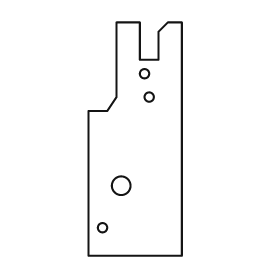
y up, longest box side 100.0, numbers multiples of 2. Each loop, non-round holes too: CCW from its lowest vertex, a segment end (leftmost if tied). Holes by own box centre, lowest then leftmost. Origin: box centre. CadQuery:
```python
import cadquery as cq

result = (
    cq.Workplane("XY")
    .moveTo(-20.0, -50.0)
    .lineTo(20.0, -50.0)
    .lineTo(20.0, 50.0)
    .lineTo(14.0, 50.0)
    .lineTo(10.0, 46.0)
    .lineTo(10.0, 34.0)
    .lineTo(2.0, 34.0)
    .lineTo(2.0, 50.0)
    .lineTo(-8.0, 50.0)
    .lineTo(-8.0, 18.0)
    .lineTo(-12.0, 12.0)
    .lineTo(-20.0, 12.0)
    .close()
    .moveTo(-14.0, -38.0)
    .circle(2.0)
    .moveTo(-6.0, -20.0)
    .circle(4.0)
    .moveTo(6.0, 18.0)
    .circle(2.0)
    .moveTo(4.0, 28.0)
    .circle(2.0)
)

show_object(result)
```